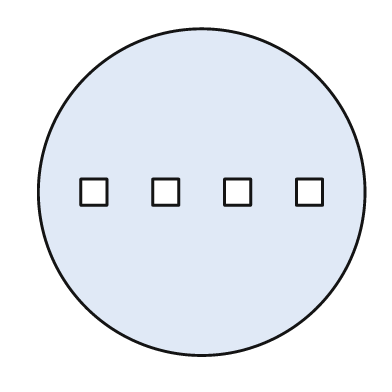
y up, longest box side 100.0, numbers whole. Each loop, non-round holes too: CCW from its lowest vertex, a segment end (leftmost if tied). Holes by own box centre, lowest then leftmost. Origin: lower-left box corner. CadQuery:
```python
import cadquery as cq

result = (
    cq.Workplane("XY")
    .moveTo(50.0, 50.0)
    .circle(50.0)
    .moveTo(13.0, 46.0)
    .lineTo(21.0, 46.0)
    .lineTo(21.0, 54.0)
    .lineTo(13.0, 54.0)
    .close()
    .moveTo(35.0, 46.0)
    .lineTo(43.0, 46.0)
    .lineTo(43.0, 54.0)
    .lineTo(35.0, 54.0)
    .close()
    .moveTo(57.0, 46.0)
    .lineTo(65.0, 46.0)
    .lineTo(65.0, 54.0)
    .lineTo(57.0, 54.0)
    .close()
    .moveTo(79.0, 46.0)
    .lineTo(87.0, 46.0)
    .lineTo(87.0, 54.0)
    .lineTo(79.0, 54.0)
    .close()
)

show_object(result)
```